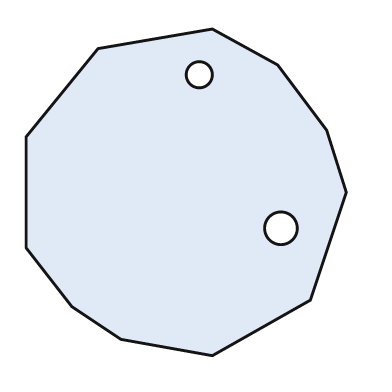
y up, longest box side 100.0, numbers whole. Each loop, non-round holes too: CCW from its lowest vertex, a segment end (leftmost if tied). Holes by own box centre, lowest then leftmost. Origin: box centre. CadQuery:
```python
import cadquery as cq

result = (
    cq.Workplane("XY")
    .moveTo(8.0, -50.0)
    .lineTo(38.0, -33.0)
    .lineTo(49.0, 0.0)
    .lineTo(43.0, 19.0)
    .lineTo(28.0, 39.0)
    .lineTo(8.0, 50.0)
    .lineTo(-27.0, 44.0)
    .lineTo(-49.0, 17.0)
    .lineTo(-49.0, -17.0)
    .lineTo(-35.0, -35.0)
    .lineTo(-20.0, -45.0)
    .close()
    .moveTo(29.0, -11.0)
    .circle(5.0)
    .moveTo(4.0, 36.0)
    .circle(4.0)
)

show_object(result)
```